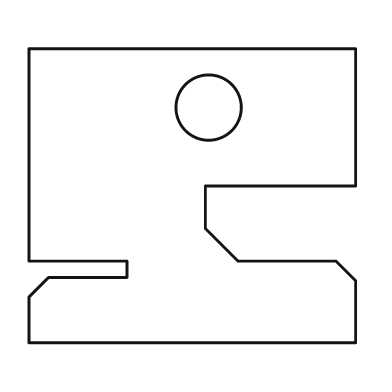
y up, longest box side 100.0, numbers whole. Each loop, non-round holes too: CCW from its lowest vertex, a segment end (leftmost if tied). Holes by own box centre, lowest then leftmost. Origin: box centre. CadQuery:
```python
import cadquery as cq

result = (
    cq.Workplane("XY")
    .moveTo(-50.0, -45.0)
    .lineTo(50.0, -45.0)
    .lineTo(50.0, -26.0)
    .lineTo(44.0, -20.0)
    .lineTo(14.0, -20.0)
    .lineTo(4.0, -10.0)
    .lineTo(4.0, 3.0)
    .lineTo(50.0, 3.0)
    .lineTo(50.0, 45.0)
    .lineTo(-50.0, 45.0)
    .lineTo(-50.0, -20.0)
    .lineTo(-20.0, -20.0)
    .lineTo(-20.0, -25.0)
    .lineTo(-44.0, -25.0)
    .lineTo(-50.0, -31.0)
    .close()
    .moveTo(5.0, 27.0)
    .circle(10.0)
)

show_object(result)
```